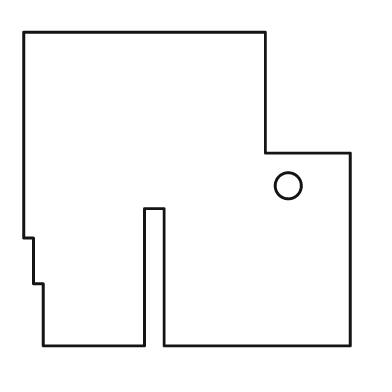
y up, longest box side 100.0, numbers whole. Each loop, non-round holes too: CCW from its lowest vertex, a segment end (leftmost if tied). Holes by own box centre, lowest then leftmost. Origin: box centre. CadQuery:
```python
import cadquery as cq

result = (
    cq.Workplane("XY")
    .moveTo(-44.0, -48.0)
    .lineTo(-13.0, -48.0)
    .lineTo(-13.0, -6.0)
    .lineTo(-7.0, -6.0)
    .lineTo(-7.0, -48.0)
    .lineTo(50.0, -48.0)
    .lineTo(50.0, 11.0)
    .lineTo(24.0, 11.0)
    .lineTo(24.0, 48.0)
    .lineTo(-50.0, 48.0)
    .lineTo(-50.0, -15.0)
    .lineTo(-47.0, -15.0)
    .lineTo(-47.0, -29.0)
    .lineTo(-44.0, -29.0)
    .close()
    .moveTo(31.0, 1.0)
    .circle(4.0)
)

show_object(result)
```